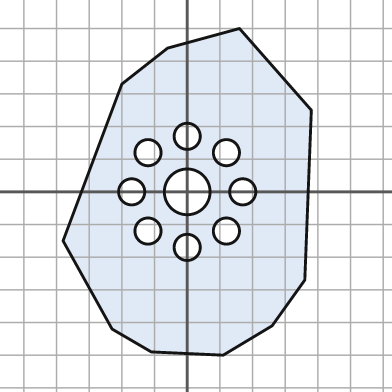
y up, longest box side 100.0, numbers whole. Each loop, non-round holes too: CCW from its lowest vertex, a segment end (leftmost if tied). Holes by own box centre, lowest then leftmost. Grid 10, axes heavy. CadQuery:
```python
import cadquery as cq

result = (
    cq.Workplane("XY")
    .moveTo(11.0, -50.0)
    .lineTo(26.0, -41.0)
    .lineTo(36.0, -27.0)
    .lineTo(38.0, 25.0)
    .lineTo(16.0, 50.0)
    .lineTo(-6.0, 44.0)
    .lineTo(-20.0, 33.0)
    .lineTo(-38.0, -15.0)
    .lineTo(-23.0, -42.0)
    .lineTo(-11.0, -49.0)
    .close()
    .moveTo(0.0, -17.0)
    .circle(4.0)
    .moveTo(-12.0, -12.0)
    .circle(4.0)
    .moveTo(12.0, -12.0)
    .circle(4.0)
    .moveTo(-17.0, 0.0)
    .circle(4.0)
    .moveTo(0.0, 0.0)
    .circle(7.0)
    .moveTo(17.0, 0.0)
    .circle(4.0)
    .moveTo(-12.0, 12.0)
    .circle(4.0)
    .moveTo(12.0, 12.0)
    .circle(4.0)
    .moveTo(0.0, 17.0)
    .circle(4.0)
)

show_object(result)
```